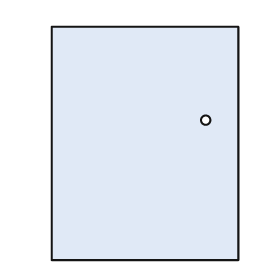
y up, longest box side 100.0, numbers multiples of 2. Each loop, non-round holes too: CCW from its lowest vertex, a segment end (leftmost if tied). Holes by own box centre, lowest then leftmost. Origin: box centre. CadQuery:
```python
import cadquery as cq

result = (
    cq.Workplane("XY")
    .moveTo(-40.0, -50.0)
    .lineTo(40.0, -50.0)
    .lineTo(40.0, 50.0)
    .lineTo(-40.0, 50.0)
    .close()
    .moveTo(26.0, 10.0)
    .circle(2.0)
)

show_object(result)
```